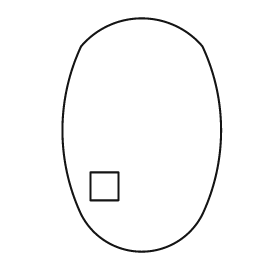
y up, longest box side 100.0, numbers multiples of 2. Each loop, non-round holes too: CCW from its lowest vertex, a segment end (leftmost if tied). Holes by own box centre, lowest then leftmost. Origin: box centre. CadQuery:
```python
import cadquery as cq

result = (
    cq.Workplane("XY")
    .moveTo(-26.0, -34.0)
    .threePointArc((0.0, -50.0), (26.0, -34.0))
    .threePointArc((34.0, 2.0), (26.0, 38.0))
    .threePointArc((0.0, 50.0), (-26.0, 38.0))
    .threePointArc((-34.0, 2.0), (-26.0, -34.0))
    .close()
    .moveTo(-22.0, -28.0)
    .lineTo(-10.0, -28.0)
    .lineTo(-10.0, -16.0)
    .lineTo(-22.0, -16.0)
    .close()
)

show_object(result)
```